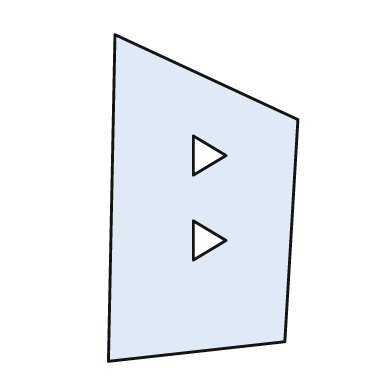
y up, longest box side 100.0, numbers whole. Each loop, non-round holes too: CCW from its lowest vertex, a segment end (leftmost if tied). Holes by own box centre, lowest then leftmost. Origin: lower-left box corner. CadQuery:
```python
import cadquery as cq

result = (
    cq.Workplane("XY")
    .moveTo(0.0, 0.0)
    .lineTo(54.0, 6.0)
    .lineTo(58.0, 74.0)
    .lineTo(2.0, 100.0)
    .close()
    .moveTo(26.0, 31.0)
    .lineTo(36.0, 37.0)
    .lineTo(26.0, 43.0)
    .close()
    .moveTo(26.0, 57.0)
    .lineTo(36.0, 63.0)
    .lineTo(26.0, 69.0)
    .close()
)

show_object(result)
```